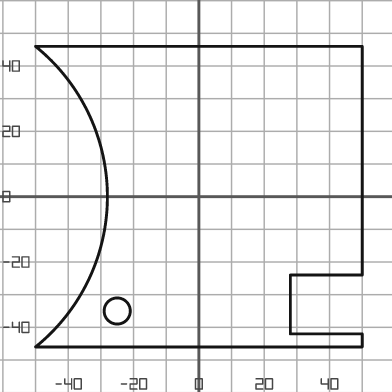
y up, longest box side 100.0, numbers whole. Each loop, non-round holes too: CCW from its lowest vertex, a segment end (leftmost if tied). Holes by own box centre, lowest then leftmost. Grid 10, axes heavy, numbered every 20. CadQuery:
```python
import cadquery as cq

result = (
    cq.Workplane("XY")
    .moveTo(-50.0, -46.0)
    .lineTo(50.0, -46.0)
    .lineTo(50.0, -42.0)
    .lineTo(28.0, -42.0)
    .lineTo(28.0, -24.0)
    .lineTo(50.0, -24.0)
    .lineTo(50.0, 46.0)
    .lineTo(-50.0, 46.0)
    .threePointArc((-28.0, 0.0), (-50.0, -46.0))
    .close()
    .moveTo(-25.0, -35.0)
    .circle(4.0)
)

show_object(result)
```